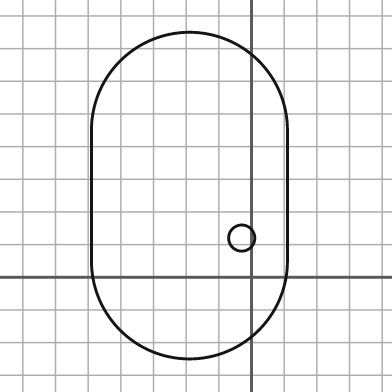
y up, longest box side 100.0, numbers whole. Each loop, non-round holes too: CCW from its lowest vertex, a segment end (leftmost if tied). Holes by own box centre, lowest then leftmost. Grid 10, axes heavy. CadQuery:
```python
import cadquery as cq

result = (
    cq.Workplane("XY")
    .moveTo(-49.0, 5.0)
    .threePointArc((-19.0, -25.0), (11.0, 5.0))
    .lineTo(11.0, 45.0)
    .threePointArc((-19.0, 75.0), (-49.0, 45.0))
    .close()
    .moveTo(-3.0, 12.0)
    .circle(4.0)
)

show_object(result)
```